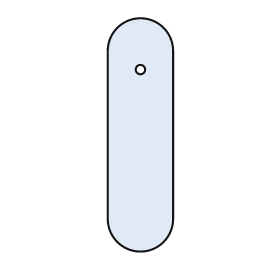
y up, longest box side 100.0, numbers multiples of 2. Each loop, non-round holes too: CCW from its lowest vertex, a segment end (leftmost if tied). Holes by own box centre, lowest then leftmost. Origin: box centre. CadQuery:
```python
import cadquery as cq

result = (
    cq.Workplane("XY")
    .moveTo(-14.0, -36.0)
    .threePointArc((0.0, -50.0), (14.0, -36.0))
    .lineTo(14.0, 36.0)
    .threePointArc((0.0, 50.0), (-14.0, 36.0))
    .close()
    .moveTo(0.0, 28.0)
    .circle(2.0)
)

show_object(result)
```